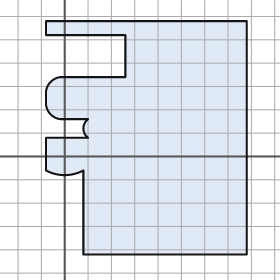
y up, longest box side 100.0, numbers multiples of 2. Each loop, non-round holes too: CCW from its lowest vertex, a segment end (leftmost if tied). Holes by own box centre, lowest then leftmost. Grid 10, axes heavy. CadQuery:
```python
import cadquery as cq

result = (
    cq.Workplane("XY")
    .moveTo(8.0, -42.0)
    .lineTo(78.0, -42.0)
    .lineTo(78.0, 58.0)
    .lineTo(-8.0, 58.0)
    .lineTo(-8.0, 52.0)
    .lineTo(26.0, 52.0)
    .lineTo(26.0, 34.0)
    .lineTo(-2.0, 34.0)
    .threePointArc((-6.0, 32.0), (-8.0, 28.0))
    .lineTo(-8.0, 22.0)
    .threePointArc((-6.0, 18.0), (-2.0, 16.0))
    .lineTo(10.0, 16.0)
    .threePointArc((8.0, 12.0), (10.0, 8.0))
    .lineTo(-8.0, 8.0)
    .lineTo(-8.0, -6.0)
    .threePointArc((0.0, -8.0), (8.0, -6.0))
    .close()
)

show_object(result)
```